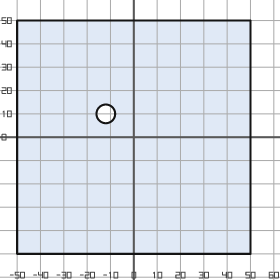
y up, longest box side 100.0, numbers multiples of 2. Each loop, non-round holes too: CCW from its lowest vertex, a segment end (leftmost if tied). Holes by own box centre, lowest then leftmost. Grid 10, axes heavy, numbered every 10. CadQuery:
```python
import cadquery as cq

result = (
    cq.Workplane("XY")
    .moveTo(-50.0, -50.0)
    .lineTo(50.0, -50.0)
    .lineTo(50.0, 50.0)
    .lineTo(-50.0, 50.0)
    .close()
    .moveTo(-12.0, 10.0)
    .circle(4.0)
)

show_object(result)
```